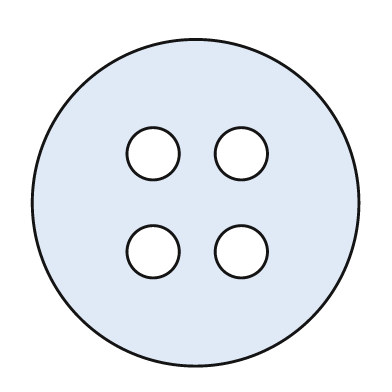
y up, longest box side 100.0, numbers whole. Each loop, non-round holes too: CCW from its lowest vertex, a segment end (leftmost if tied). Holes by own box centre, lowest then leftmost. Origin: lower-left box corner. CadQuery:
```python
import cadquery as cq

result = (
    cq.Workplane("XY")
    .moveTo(50.0, 50.0)
    .circle(50.0)
    .moveTo(37.0, 35.0)
    .circle(8.0)
    .moveTo(64.0, 35.0)
    .circle(8.0)
    .moveTo(37.0, 65.0)
    .circle(8.0)
    .moveTo(64.0, 65.0)
    .circle(8.0)
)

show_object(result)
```